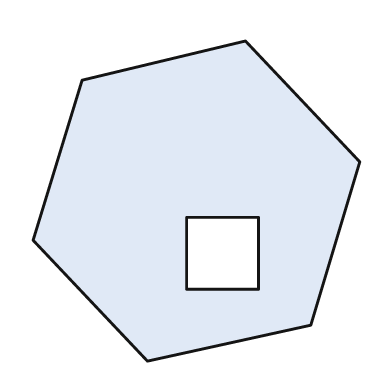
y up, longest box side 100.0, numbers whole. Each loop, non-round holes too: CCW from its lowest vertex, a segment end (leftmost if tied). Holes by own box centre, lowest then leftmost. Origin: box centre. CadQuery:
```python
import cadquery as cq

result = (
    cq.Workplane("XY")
    .moveTo(-15.0, -49.0)
    .lineTo(35.0, -38.0)
    .lineTo(50.0, 12.0)
    .lineTo(15.0, 49.0)
    .lineTo(-35.0, 37.0)
    .lineTo(-50.0, -12.0)
    .close()
    .moveTo(-3.0, -27.0)
    .lineTo(19.0, -27.0)
    .lineTo(19.0, -5.0)
    .lineTo(-3.0, -5.0)
    .close()
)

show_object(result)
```